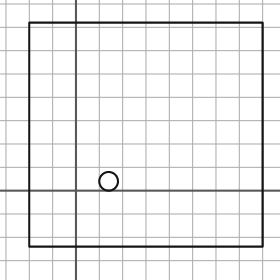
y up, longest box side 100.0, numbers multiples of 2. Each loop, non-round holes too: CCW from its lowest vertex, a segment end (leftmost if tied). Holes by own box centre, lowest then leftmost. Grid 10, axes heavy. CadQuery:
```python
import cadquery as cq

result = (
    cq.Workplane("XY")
    .moveTo(-20.0, -24.0)
    .lineTo(80.0, -24.0)
    .lineTo(80.0, 72.0)
    .lineTo(-20.0, 72.0)
    .close()
    .moveTo(14.0, 4.0)
    .circle(4.0)
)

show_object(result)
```